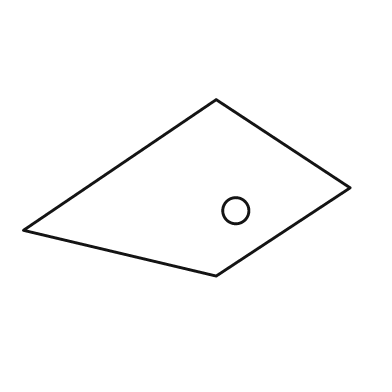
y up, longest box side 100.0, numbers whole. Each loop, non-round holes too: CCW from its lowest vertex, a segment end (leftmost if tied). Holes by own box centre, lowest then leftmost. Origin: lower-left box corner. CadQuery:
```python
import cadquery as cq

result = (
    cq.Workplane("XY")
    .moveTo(59.0, 0.0)
    .lineTo(100.0, 27.0)
    .lineTo(59.0, 54.0)
    .lineTo(0.0, 14.0)
    .close()
    .moveTo(65.0, 20.0)
    .circle(4.0)
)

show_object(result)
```